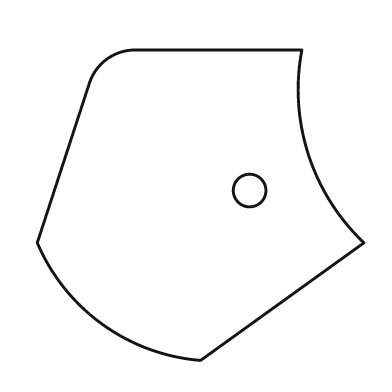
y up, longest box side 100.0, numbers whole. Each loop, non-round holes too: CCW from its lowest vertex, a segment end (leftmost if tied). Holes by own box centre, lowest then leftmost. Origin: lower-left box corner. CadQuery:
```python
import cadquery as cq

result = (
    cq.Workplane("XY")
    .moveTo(50.0, 0.0)
    .lineTo(100.0, 36.0)
    .threePointArc((83.0, 63.0), (81.0, 95.0))
    .lineTo(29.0, 95.0)
    .threePointArc((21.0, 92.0), (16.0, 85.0))
    .lineTo(0.0, 36.0)
    .threePointArc((20.0, 11.0), (50.0, 0.0))
    .close()
    .moveTo(65.0, 52.0)
    .circle(5.0)
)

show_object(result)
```